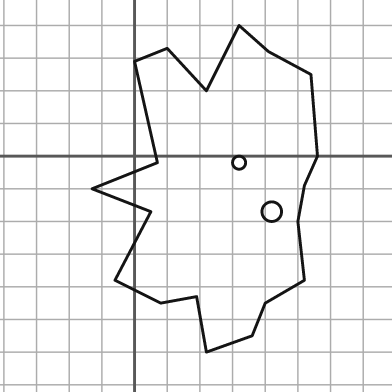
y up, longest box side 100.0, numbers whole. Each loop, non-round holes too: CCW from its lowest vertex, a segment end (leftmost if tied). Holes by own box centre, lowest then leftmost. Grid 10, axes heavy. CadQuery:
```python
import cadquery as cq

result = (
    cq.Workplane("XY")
    .moveTo(22.0, -60.0)
    .lineTo(36.0, -55.0)
    .lineTo(40.0, -45.0)
    .lineTo(52.0, -38.0)
    .lineTo(50.0, -20.0)
    .lineTo(52.0, -9.0)
    .lineTo(56.0, 0.0)
    .lineTo(54.0, 25.0)
    .lineTo(41.0, 32.0)
    .lineTo(32.0, 40.0)
    .lineTo(22.0, 20.0)
    .lineTo(10.0, 33.0)
    .lineTo(0.0, 29.0)
    .lineTo(7.0, -2.0)
    .lineTo(-13.0, -10.0)
    .lineTo(5.0, -17.0)
    .lineTo(-6.0, -38.0)
    .lineTo(8.0, -45.0)
    .lineTo(19.0, -43.0)
    .close()
    .moveTo(42.0, -17.0)
    .circle(3.0)
    .moveTo(32.0, -2.0)
    .circle(2.0)
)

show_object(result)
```